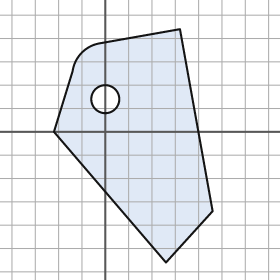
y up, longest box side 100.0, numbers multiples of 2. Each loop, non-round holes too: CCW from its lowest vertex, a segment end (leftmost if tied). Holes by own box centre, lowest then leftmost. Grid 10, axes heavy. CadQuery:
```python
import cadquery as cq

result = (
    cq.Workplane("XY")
    .moveTo(26.0, -56.0)
    .lineTo(46.0, -34.0)
    .lineTo(32.0, 44.0)
    .lineTo(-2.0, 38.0)
    .threePointArc((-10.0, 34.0), (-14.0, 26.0))
    .lineTo(-22.0, 0.0)
    .close()
    .moveTo(0.0, 14.0)
    .circle(6.0)
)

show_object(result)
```